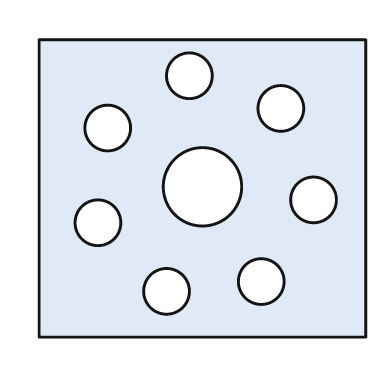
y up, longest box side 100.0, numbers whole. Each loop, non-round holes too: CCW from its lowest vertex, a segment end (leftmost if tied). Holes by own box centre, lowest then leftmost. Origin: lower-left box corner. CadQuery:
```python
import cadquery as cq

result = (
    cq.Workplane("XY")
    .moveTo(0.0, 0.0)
    .lineTo(100.0, 0.0)
    .lineTo(100.0, 91.0)
    .lineTo(0.0, 91.0)
    .close()
    .moveTo(39.0, 14.0)
    .circle(7.0)
    .moveTo(68.0, 17.0)
    .circle(7.0)
    .moveTo(18.0, 35.0)
    .circle(7.0)
    .moveTo(84.0, 42.0)
    .circle(7.0)
    .moveTo(50.0, 46.0)
    .circle(12.0)
    .moveTo(21.0, 64.0)
    .circle(7.0)
    .moveTo(74.0, 70.0)
    .circle(7.0)
    .moveTo(46.0, 80.0)
    .circle(7.0)
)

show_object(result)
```